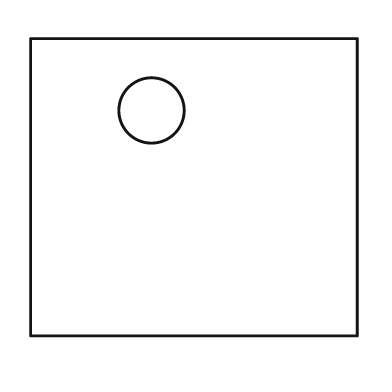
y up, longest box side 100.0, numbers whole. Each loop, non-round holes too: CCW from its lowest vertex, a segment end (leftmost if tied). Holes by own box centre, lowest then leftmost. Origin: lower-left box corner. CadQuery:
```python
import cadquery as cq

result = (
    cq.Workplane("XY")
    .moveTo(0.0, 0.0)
    .lineTo(100.0, 0.0)
    .lineTo(100.0, 91.0)
    .lineTo(0.0, 91.0)
    .close()
    .moveTo(37.0, 69.0)
    .circle(10.0)
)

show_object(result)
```